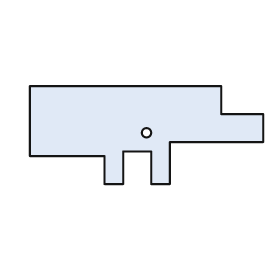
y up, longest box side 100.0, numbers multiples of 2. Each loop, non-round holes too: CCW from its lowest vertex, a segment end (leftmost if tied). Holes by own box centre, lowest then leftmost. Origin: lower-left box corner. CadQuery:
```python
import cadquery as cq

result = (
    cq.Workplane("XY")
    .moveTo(32.0, 0.0)
    .lineTo(40.0, 0.0)
    .lineTo(40.0, 14.0)
    .lineTo(52.0, 14.0)
    .lineTo(52.0, 0.0)
    .lineTo(60.0, 0.0)
    .lineTo(60.0, 18.0)
    .lineTo(100.0, 18.0)
    .lineTo(100.0, 30.0)
    .lineTo(82.0, 30.0)
    .lineTo(82.0, 42.0)
    .lineTo(0.0, 42.0)
    .lineTo(0.0, 12.0)
    .lineTo(32.0, 12.0)
    .close()
    .moveTo(50.0, 22.0)
    .circle(2.0)
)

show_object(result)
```